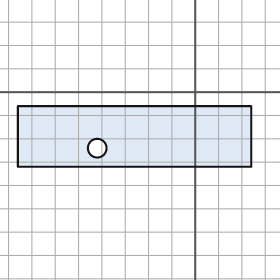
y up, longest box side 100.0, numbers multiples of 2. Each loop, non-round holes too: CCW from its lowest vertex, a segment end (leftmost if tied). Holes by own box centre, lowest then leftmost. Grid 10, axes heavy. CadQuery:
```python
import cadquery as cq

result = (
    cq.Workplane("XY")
    .moveTo(-76.0, -32.0)
    .lineTo(24.0, -32.0)
    .lineTo(24.0, -6.0)
    .lineTo(-76.0, -6.0)
    .close()
    .moveTo(-42.0, -24.0)
    .circle(4.0)
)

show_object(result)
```